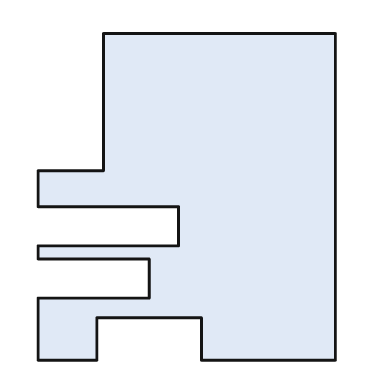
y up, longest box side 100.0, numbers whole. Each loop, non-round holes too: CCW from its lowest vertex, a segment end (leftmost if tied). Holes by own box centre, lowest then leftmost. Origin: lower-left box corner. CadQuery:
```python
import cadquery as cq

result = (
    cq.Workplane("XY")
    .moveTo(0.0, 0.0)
    .lineTo(18.0, 0.0)
    .lineTo(18.0, 13.0)
    .lineTo(50.0, 13.0)
    .lineTo(50.0, 0.0)
    .lineTo(91.0, 0.0)
    .lineTo(91.0, 100.0)
    .lineTo(20.0, 100.0)
    .lineTo(20.0, 58.0)
    .lineTo(0.0, 58.0)
    .lineTo(0.0, 47.0)
    .lineTo(43.0, 47.0)
    .lineTo(43.0, 35.0)
    .lineTo(0.0, 35.0)
    .lineTo(0.0, 31.0)
    .lineTo(34.0, 31.0)
    .lineTo(34.0, 19.0)
    .lineTo(0.0, 19.0)
    .close()
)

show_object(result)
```